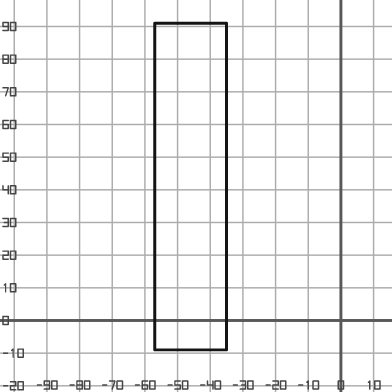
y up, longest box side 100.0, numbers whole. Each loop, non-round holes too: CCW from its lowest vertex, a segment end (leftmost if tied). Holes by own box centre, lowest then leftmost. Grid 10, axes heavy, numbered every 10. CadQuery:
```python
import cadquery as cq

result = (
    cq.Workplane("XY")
    .moveTo(-57.0, -9.0)
    .lineTo(-35.0, -9.0)
    .lineTo(-35.0, 91.0)
    .lineTo(-57.0, 91.0)
    .close()
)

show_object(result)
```